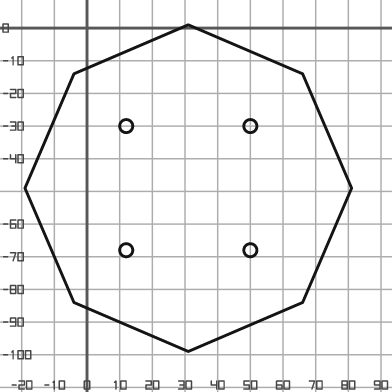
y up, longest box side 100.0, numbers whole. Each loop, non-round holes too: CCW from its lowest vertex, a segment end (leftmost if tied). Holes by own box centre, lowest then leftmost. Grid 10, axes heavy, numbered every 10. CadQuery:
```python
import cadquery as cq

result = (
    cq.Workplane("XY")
    .moveTo(31.0, -99.0)
    .lineTo(66.0, -84.0)
    .lineTo(81.0, -49.0)
    .lineTo(66.0, -14.0)
    .lineTo(31.0, 1.0)
    .lineTo(-4.0, -14.0)
    .lineTo(-19.0, -49.0)
    .lineTo(-4.0, -84.0)
    .close()
    .moveTo(12.0, -68.0)
    .circle(2.0)
    .moveTo(50.0, -68.0)
    .circle(2.0)
    .moveTo(12.0, -30.0)
    .circle(2.0)
    .moveTo(50.0, -30.0)
    .circle(2.0)
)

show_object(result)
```